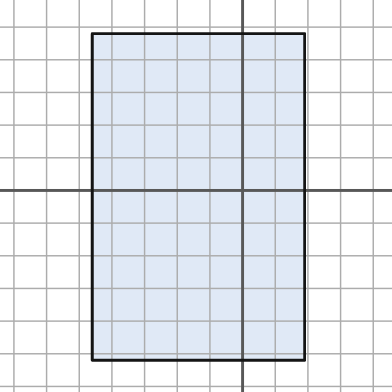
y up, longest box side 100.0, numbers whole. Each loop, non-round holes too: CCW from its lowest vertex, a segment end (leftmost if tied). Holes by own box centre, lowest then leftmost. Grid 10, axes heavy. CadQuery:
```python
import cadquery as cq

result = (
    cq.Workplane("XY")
    .moveTo(-46.0, -52.0)
    .lineTo(19.0, -52.0)
    .lineTo(19.0, 48.0)
    .lineTo(-46.0, 48.0)
    .close()
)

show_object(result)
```